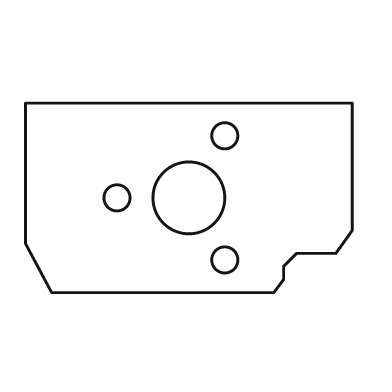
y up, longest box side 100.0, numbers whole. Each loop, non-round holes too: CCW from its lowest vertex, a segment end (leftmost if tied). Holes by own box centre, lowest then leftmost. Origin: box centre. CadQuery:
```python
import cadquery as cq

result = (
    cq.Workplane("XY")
    .moveTo(-42.0, -29.0)
    .lineTo(26.0, -29.0)
    .lineTo(29.0, -25.0)
    .lineTo(29.0, -21.0)
    .lineTo(33.0, -17.0)
    .lineTo(45.0, -17.0)
    .lineTo(50.0, -10.0)
    .lineTo(50.0, 29.0)
    .lineTo(-50.0, 29.0)
    .lineTo(-50.0, -14.0)
    .close()
    .moveTo(11.0, -19.0)
    .circle(4.0)
    .moveTo(-22.0, 0.0)
    .circle(4.0)
    .moveTo(0.0, 0.0)
    .circle(11.0)
    .moveTo(11.0, 19.0)
    .circle(4.0)
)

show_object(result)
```